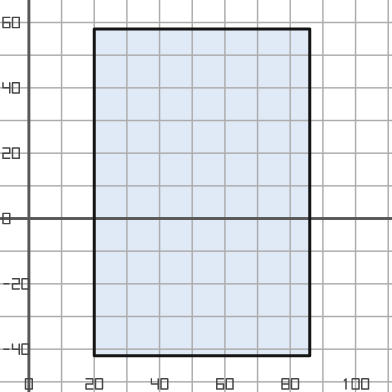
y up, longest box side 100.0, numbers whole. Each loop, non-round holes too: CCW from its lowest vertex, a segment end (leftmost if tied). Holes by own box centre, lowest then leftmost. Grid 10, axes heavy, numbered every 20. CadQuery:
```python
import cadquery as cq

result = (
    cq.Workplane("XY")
    .moveTo(20.0, -42.0)
    .lineTo(86.0, -42.0)
    .lineTo(86.0, 58.0)
    .lineTo(20.0, 58.0)
    .close()
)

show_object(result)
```